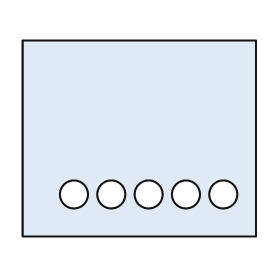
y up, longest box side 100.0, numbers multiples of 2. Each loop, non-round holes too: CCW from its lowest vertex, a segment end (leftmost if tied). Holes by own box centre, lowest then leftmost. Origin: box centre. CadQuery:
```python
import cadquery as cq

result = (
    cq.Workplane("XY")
    .moveTo(-50.0, -42.0)
    .lineTo(50.0, -42.0)
    .lineTo(50.0, 42.0)
    .lineTo(-50.0, 42.0)
    .close()
    .moveTo(-28.0, -24.0)
    .circle(6.0)
    .moveTo(-12.0, -24.0)
    .circle(6.0)
    .moveTo(4.0, -24.0)
    .circle(6.0)
    .moveTo(20.0, -24.0)
    .circle(6.0)
    .moveTo(36.0, -24.0)
    .circle(6.0)
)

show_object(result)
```